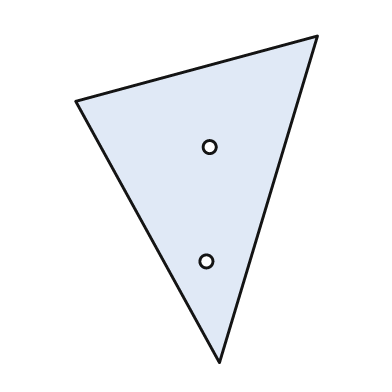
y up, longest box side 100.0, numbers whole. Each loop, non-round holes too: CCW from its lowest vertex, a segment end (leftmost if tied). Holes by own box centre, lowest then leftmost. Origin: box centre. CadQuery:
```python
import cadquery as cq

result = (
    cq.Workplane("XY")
    .moveTo(7.0, -50.0)
    .lineTo(37.0, 50.0)
    .lineTo(-37.0, 30.0)
    .close()
    .moveTo(3.0, -19.0)
    .circle(2.0)
    .moveTo(4.0, 16.0)
    .circle(2.0)
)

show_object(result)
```